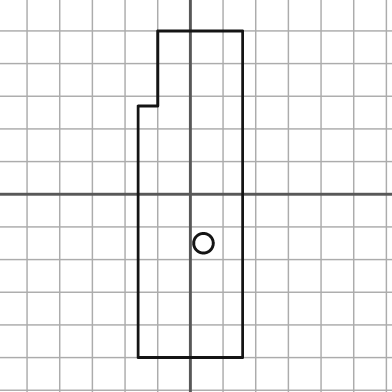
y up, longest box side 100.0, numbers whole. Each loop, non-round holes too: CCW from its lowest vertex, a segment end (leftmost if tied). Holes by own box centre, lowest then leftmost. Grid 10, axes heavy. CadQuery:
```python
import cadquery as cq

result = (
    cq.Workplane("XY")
    .moveTo(-16.0, -50.0)
    .lineTo(16.0, -50.0)
    .lineTo(16.0, 50.0)
    .lineTo(-10.0, 50.0)
    .lineTo(-10.0, 27.0)
    .lineTo(-16.0, 27.0)
    .close()
    .moveTo(4.0, -15.0)
    .circle(3.0)
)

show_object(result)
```